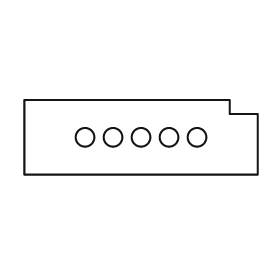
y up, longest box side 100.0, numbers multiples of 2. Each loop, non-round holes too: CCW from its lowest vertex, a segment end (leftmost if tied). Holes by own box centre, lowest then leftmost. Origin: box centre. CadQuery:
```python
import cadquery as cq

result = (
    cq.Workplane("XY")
    .moveTo(-50.0, -16.0)
    .lineTo(50.0, -16.0)
    .lineTo(50.0, 10.0)
    .lineTo(38.0, 10.0)
    .lineTo(38.0, 16.0)
    .lineTo(-50.0, 16.0)
    .close()
    .moveTo(-24.0, 0.0)
    .circle(4.0)
    .moveTo(-12.0, 0.0)
    .circle(4.0)
    .moveTo(0.0, 0.0)
    .circle(4.0)
    .moveTo(12.0, 0.0)
    .circle(4.0)
    .moveTo(24.0, 0.0)
    .circle(4.0)
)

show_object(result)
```